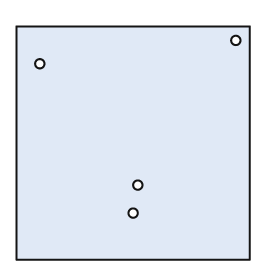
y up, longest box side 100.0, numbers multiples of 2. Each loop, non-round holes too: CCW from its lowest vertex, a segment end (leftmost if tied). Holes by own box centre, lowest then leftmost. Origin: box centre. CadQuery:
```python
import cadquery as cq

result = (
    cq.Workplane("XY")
    .moveTo(-50.0, -50.0)
    .lineTo(50.0, -50.0)
    .lineTo(50.0, 50.0)
    .lineTo(-50.0, 50.0)
    .close()
    .moveTo(0.0, -30.0)
    .circle(2.0)
    .moveTo(2.0, -18.0)
    .circle(2.0)
    .moveTo(-40.0, 34.0)
    .circle(2.0)
    .moveTo(44.0, 44.0)
    .circle(2.0)
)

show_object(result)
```